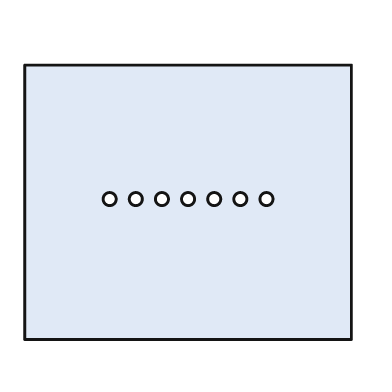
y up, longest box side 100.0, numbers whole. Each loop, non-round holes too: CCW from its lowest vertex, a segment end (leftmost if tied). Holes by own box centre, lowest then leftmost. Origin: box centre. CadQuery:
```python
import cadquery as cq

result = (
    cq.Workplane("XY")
    .moveTo(-50.0, -42.0)
    .lineTo(50.0, -42.0)
    .lineTo(50.0, 42.0)
    .lineTo(-50.0, 42.0)
    .close()
    .moveTo(-24.0, 1.0)
    .circle(2.0)
    .moveTo(-16.0, 1.0)
    .circle(2.0)
    .moveTo(-8.0, 1.0)
    .circle(2.0)
    .moveTo(0.0, 1.0)
    .circle(2.0)
    .moveTo(8.0, 1.0)
    .circle(2.0)
    .moveTo(16.0, 1.0)
    .circle(2.0)
    .moveTo(24.0, 1.0)
    .circle(2.0)
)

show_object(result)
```